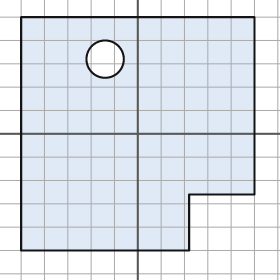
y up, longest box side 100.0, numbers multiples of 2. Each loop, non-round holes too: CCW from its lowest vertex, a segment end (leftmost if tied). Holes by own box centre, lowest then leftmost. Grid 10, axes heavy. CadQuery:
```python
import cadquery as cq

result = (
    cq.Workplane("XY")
    .moveTo(-50.0, -50.0)
    .lineTo(22.0, -50.0)
    .lineTo(22.0, -26.0)
    .lineTo(50.0, -26.0)
    .lineTo(50.0, 50.0)
    .lineTo(-50.0, 50.0)
    .close()
    .moveTo(-14.0, 32.0)
    .circle(8.0)
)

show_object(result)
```